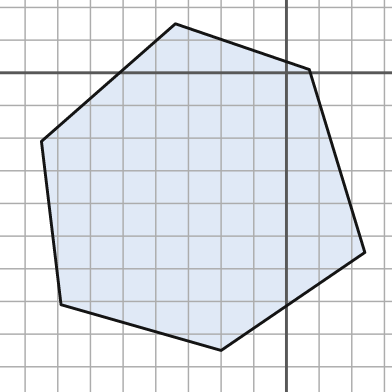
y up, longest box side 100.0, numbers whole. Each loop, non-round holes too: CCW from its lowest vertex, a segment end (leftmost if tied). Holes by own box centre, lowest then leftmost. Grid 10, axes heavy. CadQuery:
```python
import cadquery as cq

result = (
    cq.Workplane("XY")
    .moveTo(-20.0, -85.0)
    .lineTo(24.0, -55.0)
    .lineTo(7.0, 1.0)
    .lineTo(-34.0, 15.0)
    .lineTo(-75.0, -21.0)
    .lineTo(-69.0, -71.0)
    .close()
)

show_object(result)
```